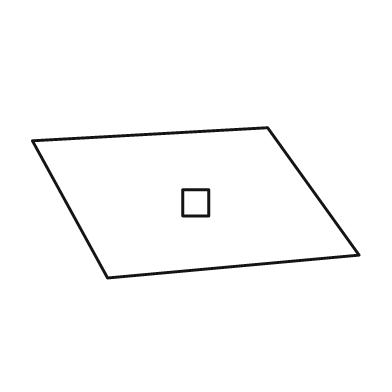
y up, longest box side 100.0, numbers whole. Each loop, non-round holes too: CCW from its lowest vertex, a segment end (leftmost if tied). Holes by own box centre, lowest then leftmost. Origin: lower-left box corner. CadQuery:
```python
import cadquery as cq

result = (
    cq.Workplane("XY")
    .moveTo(23.0, 0.0)
    .lineTo(100.0, 7.0)
    .lineTo(72.0, 46.0)
    .lineTo(0.0, 42.0)
    .close()
    .moveTo(46.0, 19.0)
    .lineTo(54.0, 19.0)
    .lineTo(54.0, 27.0)
    .lineTo(46.0, 27.0)
    .close()
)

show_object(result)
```